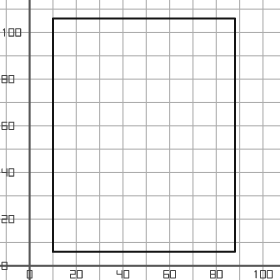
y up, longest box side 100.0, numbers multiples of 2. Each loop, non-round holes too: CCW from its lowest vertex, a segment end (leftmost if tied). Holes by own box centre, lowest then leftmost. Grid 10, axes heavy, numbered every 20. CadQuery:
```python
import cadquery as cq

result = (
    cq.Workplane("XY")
    .moveTo(10.0, 6.0)
    .lineTo(88.0, 6.0)
    .lineTo(88.0, 106.0)
    .lineTo(10.0, 106.0)
    .close()
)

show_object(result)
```